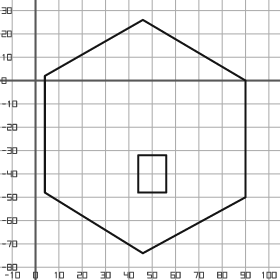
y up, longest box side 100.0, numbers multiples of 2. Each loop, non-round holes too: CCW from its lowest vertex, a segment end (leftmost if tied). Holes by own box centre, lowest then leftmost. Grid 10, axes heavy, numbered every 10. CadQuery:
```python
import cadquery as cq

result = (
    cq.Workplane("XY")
    .moveTo(46.0, -74.0)
    .lineTo(90.0, -50.0)
    .lineTo(90.0, 0.0)
    .lineTo(46.0, 26.0)
    .lineTo(4.0, 2.0)
    .lineTo(4.0, -48.0)
    .close()
    .moveTo(44.0, -48.0)
    .lineTo(56.0, -48.0)
    .lineTo(56.0, -32.0)
    .lineTo(44.0, -32.0)
    .close()
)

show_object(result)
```